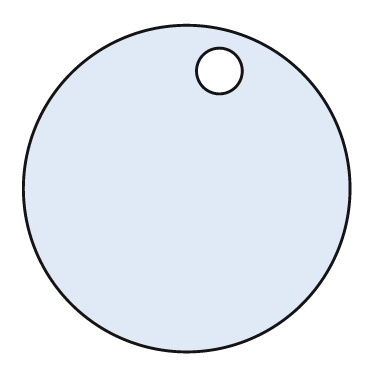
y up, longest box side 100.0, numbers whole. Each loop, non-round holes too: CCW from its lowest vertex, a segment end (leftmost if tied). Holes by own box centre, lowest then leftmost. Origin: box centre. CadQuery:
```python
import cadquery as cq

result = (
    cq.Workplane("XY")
    .moveTo(0.0, 0.0)
    .circle(50.0)
    .moveTo(10.0, 36.0)
    .circle(7.0)
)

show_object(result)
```